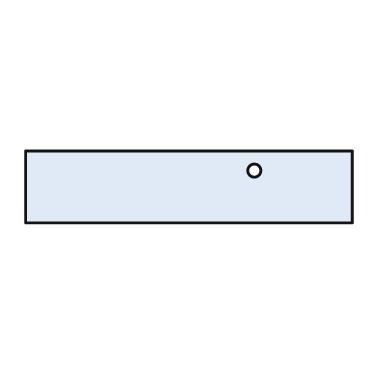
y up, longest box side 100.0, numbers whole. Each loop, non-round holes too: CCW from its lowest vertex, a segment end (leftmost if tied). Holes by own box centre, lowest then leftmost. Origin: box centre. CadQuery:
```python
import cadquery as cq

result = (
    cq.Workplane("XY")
    .moveTo(-50.0, -11.0)
    .lineTo(50.0, -11.0)
    .lineTo(50.0, 11.0)
    .lineTo(-50.0, 11.0)
    .close()
    .moveTo(20.0, 5.0)
    .circle(2.0)
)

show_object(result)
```